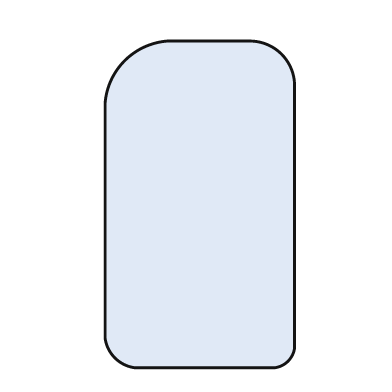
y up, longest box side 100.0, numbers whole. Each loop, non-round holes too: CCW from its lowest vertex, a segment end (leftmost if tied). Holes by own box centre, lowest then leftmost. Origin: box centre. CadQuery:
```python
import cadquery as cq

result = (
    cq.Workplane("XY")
    .moveTo(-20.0, -50.0)
    .lineTo(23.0, -50.0)
    .threePointArc((27.0, -48.0), (29.0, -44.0))
    .lineTo(29.0, 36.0)
    .threePointArc((25.0, 46.0), (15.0, 50.0))
    .lineTo(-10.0, 50.0)
    .threePointArc((-23.0, 44.0), (-29.0, 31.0))
    .lineTo(-29.0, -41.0)
    .threePointArc((-26.0, -47.0), (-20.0, -50.0))
    .close()
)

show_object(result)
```